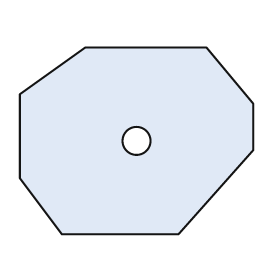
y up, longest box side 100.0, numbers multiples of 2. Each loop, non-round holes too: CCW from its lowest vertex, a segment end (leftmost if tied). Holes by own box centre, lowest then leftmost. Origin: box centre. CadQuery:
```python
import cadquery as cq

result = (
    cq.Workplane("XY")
    .moveTo(-32.0, -40.0)
    .lineTo(18.0, -40.0)
    .lineTo(50.0, -4.0)
    .lineTo(50.0, 16.0)
    .lineTo(30.0, 40.0)
    .lineTo(-22.0, 40.0)
    .lineTo(-50.0, 20.0)
    .lineTo(-50.0, -16.0)
    .close()
    .moveTo(0.0, 0.0)
    .circle(6.0)
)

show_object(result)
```